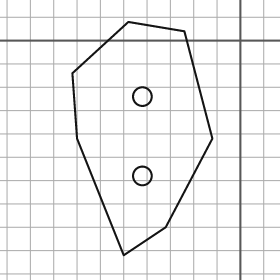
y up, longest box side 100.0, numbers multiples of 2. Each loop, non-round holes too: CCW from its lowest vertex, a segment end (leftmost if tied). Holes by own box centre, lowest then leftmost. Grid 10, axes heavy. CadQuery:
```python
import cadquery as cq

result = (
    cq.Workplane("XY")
    .moveTo(-50.0, -92.0)
    .lineTo(-32.0, -80.0)
    .lineTo(-12.0, -42.0)
    .lineTo(-24.0, 4.0)
    .lineTo(-48.0, 8.0)
    .lineTo(-72.0, -14.0)
    .lineTo(-70.0, -42.0)
    .close()
    .moveTo(-42.0, -58.0)
    .circle(4.0)
    .moveTo(-42.0, -24.0)
    .circle(4.0)
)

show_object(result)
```